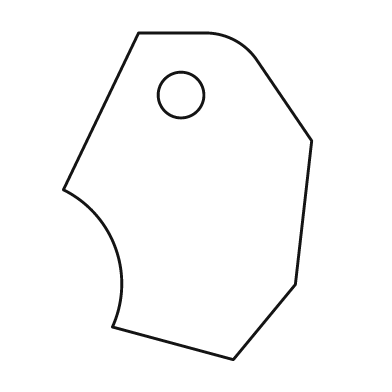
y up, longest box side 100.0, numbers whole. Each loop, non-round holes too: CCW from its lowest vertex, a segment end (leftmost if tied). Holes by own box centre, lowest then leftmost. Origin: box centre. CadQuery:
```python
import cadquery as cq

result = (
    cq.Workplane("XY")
    .moveTo(14.0, -50.0)
    .lineTo(33.0, -27.0)
    .lineTo(38.0, 17.0)
    .lineTo(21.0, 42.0)
    .threePointArc((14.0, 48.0), (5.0, 50.0))
    .lineTo(-15.0, 50.0)
    .lineTo(-38.0, 2.0)
    .threePointArc((-22.0, -16.0), (-23.0, -40.0))
    .close()
    .moveTo(-2.0, 31.0)
    .circle(7.0)
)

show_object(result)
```